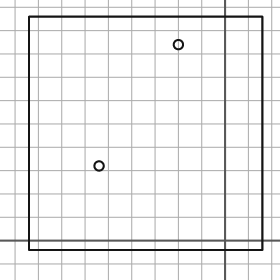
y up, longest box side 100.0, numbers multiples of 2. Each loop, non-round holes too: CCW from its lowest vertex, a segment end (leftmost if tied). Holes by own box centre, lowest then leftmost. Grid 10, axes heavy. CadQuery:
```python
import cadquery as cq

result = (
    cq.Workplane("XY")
    .moveTo(-84.0, -4.0)
    .lineTo(16.0, -4.0)
    .lineTo(16.0, 96.0)
    .lineTo(-84.0, 96.0)
    .close()
    .moveTo(-54.0, 32.0)
    .circle(2.0)
    .moveTo(-20.0, 84.0)
    .circle(2.0)
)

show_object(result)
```